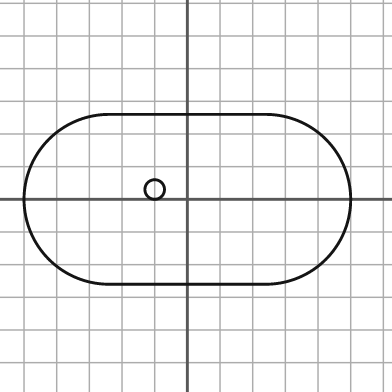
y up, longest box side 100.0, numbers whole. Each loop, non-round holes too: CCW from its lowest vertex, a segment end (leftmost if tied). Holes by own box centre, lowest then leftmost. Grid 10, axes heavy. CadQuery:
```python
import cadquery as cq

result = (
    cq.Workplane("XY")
    .moveTo(-24.0, -26.0)
    .lineTo(24.0, -26.0)
    .threePointArc((50.0, 0.0), (24.0, 26.0))
    .lineTo(-24.0, 26.0)
    .threePointArc((-50.0, 0.0), (-24.0, -26.0))
    .close()
    .moveTo(-10.0, 3.0)
    .circle(3.0)
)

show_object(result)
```